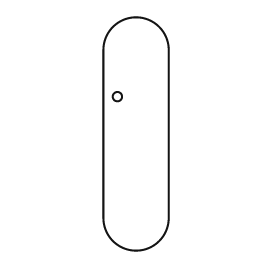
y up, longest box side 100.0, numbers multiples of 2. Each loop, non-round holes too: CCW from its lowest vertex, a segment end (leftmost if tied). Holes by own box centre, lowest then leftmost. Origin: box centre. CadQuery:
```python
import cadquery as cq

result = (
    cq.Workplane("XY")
    .moveTo(-14.0, -36.0)
    .threePointArc((0.0, -50.0), (14.0, -36.0))
    .lineTo(14.0, 36.0)
    .threePointArc((0.0, 50.0), (-14.0, 36.0))
    .close()
    .moveTo(-8.0, 16.0)
    .circle(2.0)
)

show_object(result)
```